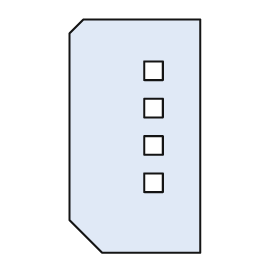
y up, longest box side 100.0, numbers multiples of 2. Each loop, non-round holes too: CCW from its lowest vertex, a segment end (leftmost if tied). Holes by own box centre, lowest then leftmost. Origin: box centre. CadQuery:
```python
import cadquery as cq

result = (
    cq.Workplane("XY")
    .moveTo(-14.0, -50.0)
    .lineTo(28.0, -50.0)
    .lineTo(28.0, 50.0)
    .lineTo(-22.0, 50.0)
    .lineTo(-28.0, 44.0)
    .lineTo(-28.0, -36.0)
    .close()
    .moveTo(4.0, -24.0)
    .lineTo(12.0, -24.0)
    .lineTo(12.0, -16.0)
    .lineTo(4.0, -16.0)
    .close()
    .moveTo(4.0, -8.0)
    .lineTo(12.0, -8.0)
    .lineTo(12.0, 0.0)
    .lineTo(4.0, 0.0)
    .close()
    .moveTo(4.0, 8.0)
    .lineTo(12.0, 8.0)
    .lineTo(12.0, 16.0)
    .lineTo(4.0, 16.0)
    .close()
    .moveTo(4.0, 24.0)
    .lineTo(12.0, 24.0)
    .lineTo(12.0, 32.0)
    .lineTo(4.0, 32.0)
    .close()
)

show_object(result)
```